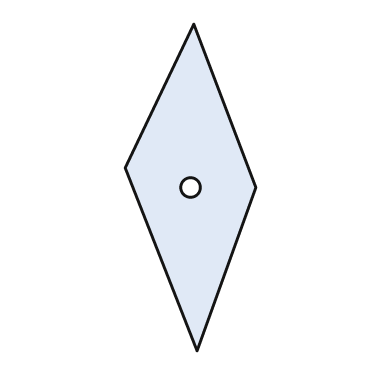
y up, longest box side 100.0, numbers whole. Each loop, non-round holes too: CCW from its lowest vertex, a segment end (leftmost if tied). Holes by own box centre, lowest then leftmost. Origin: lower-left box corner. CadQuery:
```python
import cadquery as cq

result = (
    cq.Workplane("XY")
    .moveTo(22.0, 0.0)
    .lineTo(40.0, 50.0)
    .lineTo(21.0, 100.0)
    .lineTo(0.0, 56.0)
    .close()
    .moveTo(20.0, 50.0)
    .circle(3.0)
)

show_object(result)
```